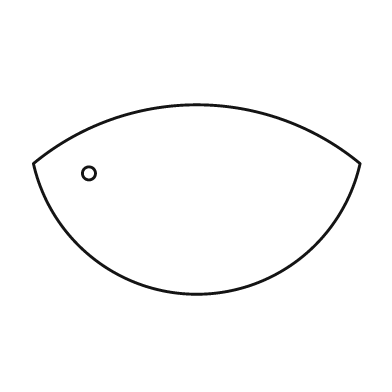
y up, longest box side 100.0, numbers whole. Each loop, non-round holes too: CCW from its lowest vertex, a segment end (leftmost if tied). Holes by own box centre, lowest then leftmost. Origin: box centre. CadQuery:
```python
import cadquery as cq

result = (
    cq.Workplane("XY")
    .moveTo(-50.0, 11.0)
    .threePointArc((0.0, -29.0), (50.0, 11.0))
    .threePointArc((0.0, 29.0), (-50.0, 11.0))
    .close()
    .moveTo(-33.0, 8.0)
    .circle(2.0)
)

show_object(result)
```